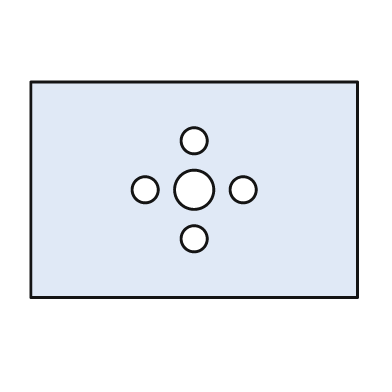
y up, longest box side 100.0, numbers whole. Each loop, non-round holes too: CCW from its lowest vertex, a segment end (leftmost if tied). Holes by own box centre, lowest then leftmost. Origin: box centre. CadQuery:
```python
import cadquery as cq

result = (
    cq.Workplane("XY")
    .moveTo(-50.0, -33.0)
    .lineTo(50.0, -33.0)
    .lineTo(50.0, 33.0)
    .lineTo(-50.0, 33.0)
    .close()
    .moveTo(0.0, -15.0)
    .circle(4.0)
    .moveTo(-15.0, 0.0)
    .circle(4.0)
    .moveTo(0.0, 0.0)
    .circle(6.0)
    .moveTo(15.0, 0.0)
    .circle(4.0)
    .moveTo(0.0, 15.0)
    .circle(4.0)
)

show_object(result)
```